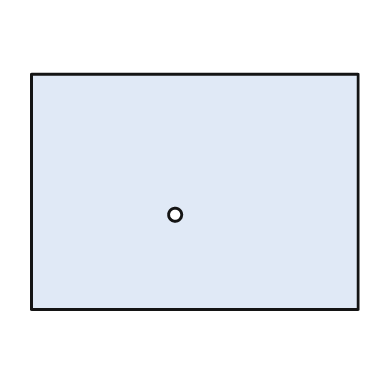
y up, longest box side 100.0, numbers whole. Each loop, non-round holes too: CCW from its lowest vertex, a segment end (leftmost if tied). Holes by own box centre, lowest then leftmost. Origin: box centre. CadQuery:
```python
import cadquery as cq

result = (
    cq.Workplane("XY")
    .moveTo(-50.0, -36.0)
    .lineTo(50.0, -36.0)
    .lineTo(50.0, 36.0)
    .lineTo(-50.0, 36.0)
    .close()
    .moveTo(-6.0, -7.0)
    .circle(2.0)
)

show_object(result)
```